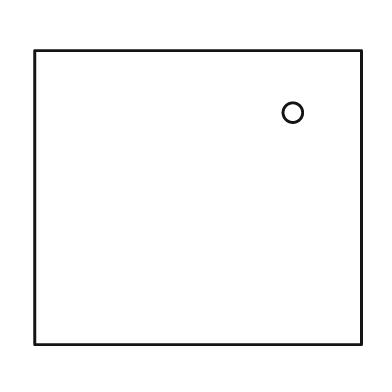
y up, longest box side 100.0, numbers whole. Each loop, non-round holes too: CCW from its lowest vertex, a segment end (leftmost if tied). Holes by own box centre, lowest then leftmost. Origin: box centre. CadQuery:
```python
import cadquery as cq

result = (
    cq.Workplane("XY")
    .moveTo(-50.0, -45.0)
    .lineTo(50.0, -45.0)
    .lineTo(50.0, 45.0)
    .lineTo(-50.0, 45.0)
    .close()
    .moveTo(29.0, 26.0)
    .circle(3.0)
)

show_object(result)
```